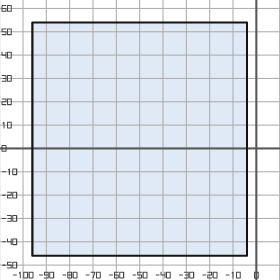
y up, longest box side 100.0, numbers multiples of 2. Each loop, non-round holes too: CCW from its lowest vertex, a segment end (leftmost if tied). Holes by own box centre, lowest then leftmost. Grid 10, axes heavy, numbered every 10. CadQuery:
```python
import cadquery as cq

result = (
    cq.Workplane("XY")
    .moveTo(-96.0, -46.0)
    .lineTo(-4.0, -46.0)
    .lineTo(-4.0, 54.0)
    .lineTo(-96.0, 54.0)
    .close()
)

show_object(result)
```